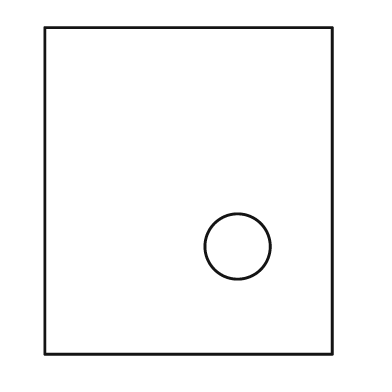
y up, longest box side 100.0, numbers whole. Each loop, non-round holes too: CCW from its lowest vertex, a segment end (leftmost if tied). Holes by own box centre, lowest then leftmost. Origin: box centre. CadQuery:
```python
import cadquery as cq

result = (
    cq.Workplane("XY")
    .moveTo(-44.0, -50.0)
    .lineTo(44.0, -50.0)
    .lineTo(44.0, 50.0)
    .lineTo(-44.0, 50.0)
    .close()
    .moveTo(15.0, -17.0)
    .circle(10.0)
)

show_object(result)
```